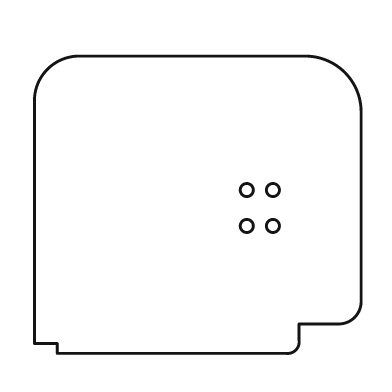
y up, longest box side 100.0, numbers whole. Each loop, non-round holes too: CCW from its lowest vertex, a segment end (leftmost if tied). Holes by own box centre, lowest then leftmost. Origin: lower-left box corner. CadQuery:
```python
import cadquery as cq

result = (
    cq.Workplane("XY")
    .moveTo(7.0, 0.0)
    .lineTo(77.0, 0.0)
    .threePointArc((80.0, 1.0), (81.0, 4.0))
    .lineTo(81.0, 9.0)
    .lineTo(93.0, 9.0)
    .threePointArc((98.0, 11.0), (100.0, 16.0))
    .lineTo(100.0, 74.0)
    .threePointArc((95.0, 86.0), (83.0, 91.0))
    .lineTo(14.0, 91.0)
    .threePointArc((4.0, 87.0), (0.0, 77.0))
    .lineTo(0.0, 3.0)
    .lineTo(7.0, 3.0)
    .close()
    .moveTo(65.0, 39.0)
    .circle(2.0)
    .moveTo(73.0, 39.0)
    .circle(2.0)
    .moveTo(65.0, 50.0)
    .circle(2.0)
    .moveTo(73.0, 50.0)
    .circle(2.0)
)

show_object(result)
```